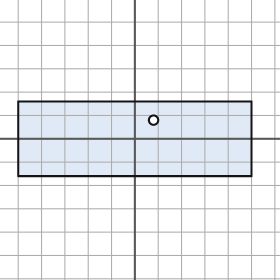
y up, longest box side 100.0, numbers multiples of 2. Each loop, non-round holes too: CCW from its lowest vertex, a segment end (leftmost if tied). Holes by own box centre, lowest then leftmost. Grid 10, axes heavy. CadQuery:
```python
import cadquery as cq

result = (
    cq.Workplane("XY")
    .moveTo(-50.0, -16.0)
    .lineTo(50.0, -16.0)
    .lineTo(50.0, 16.0)
    .lineTo(-50.0, 16.0)
    .close()
    .moveTo(8.0, 8.0)
    .circle(2.0)
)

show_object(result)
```